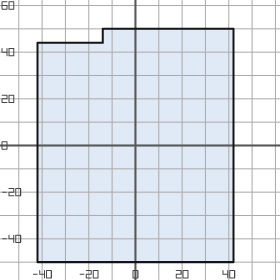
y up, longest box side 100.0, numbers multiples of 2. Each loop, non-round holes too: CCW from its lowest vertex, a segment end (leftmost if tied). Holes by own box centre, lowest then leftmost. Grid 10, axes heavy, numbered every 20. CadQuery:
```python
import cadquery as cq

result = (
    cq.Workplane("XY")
    .moveTo(-42.0, -50.0)
    .lineTo(42.0, -50.0)
    .lineTo(42.0, 50.0)
    .lineTo(-14.0, 50.0)
    .lineTo(-14.0, 44.0)
    .lineTo(-42.0, 44.0)
    .close()
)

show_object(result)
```